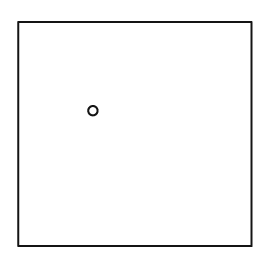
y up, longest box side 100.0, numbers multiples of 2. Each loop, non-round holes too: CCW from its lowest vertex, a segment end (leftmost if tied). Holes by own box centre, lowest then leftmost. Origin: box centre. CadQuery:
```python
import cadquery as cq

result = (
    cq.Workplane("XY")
    .moveTo(-50.0, -48.0)
    .lineTo(50.0, -48.0)
    .lineTo(50.0, 48.0)
    .lineTo(-50.0, 48.0)
    .close()
    .moveTo(-18.0, 10.0)
    .circle(2.0)
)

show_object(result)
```